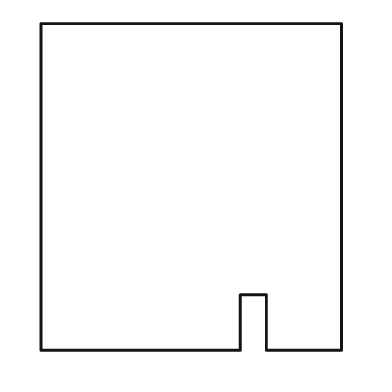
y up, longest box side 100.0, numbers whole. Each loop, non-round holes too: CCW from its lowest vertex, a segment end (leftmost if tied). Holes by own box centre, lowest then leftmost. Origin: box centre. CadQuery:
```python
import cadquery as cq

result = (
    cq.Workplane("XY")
    .moveTo(-46.0, -50.0)
    .lineTo(15.0, -50.0)
    .lineTo(15.0, -33.0)
    .lineTo(23.0, -33.0)
    .lineTo(23.0, -50.0)
    .lineTo(46.0, -50.0)
    .lineTo(46.0, 50.0)
    .lineTo(-46.0, 50.0)
    .close()
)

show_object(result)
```